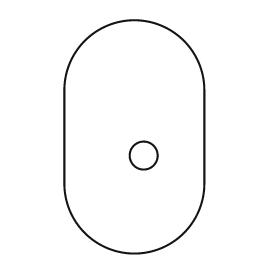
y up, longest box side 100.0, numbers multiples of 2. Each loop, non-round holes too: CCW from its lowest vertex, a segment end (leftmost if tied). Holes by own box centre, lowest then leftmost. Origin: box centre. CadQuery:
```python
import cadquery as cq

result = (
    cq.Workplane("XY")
    .moveTo(-30.0, -20.0)
    .threePointArc((0.0, -50.0), (30.0, -20.0))
    .lineTo(30.0, 20.0)
    .threePointArc((0.0, 50.0), (-30.0, 20.0))
    .close()
    .moveTo(4.0, -8.0)
    .circle(6.0)
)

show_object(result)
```